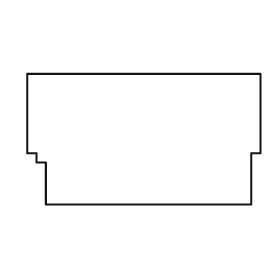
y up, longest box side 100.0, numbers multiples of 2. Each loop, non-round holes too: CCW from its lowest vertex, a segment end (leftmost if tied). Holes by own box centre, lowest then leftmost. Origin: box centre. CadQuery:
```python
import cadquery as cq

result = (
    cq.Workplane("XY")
    .moveTo(-42.0, -28.0)
    .lineTo(46.0, -28.0)
    .lineTo(46.0, -6.0)
    .lineTo(50.0, -6.0)
    .lineTo(50.0, 28.0)
    .lineTo(-50.0, 28.0)
    .lineTo(-50.0, -6.0)
    .lineTo(-46.0, -6.0)
    .lineTo(-46.0, -10.0)
    .lineTo(-42.0, -10.0)
    .close()
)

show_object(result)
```